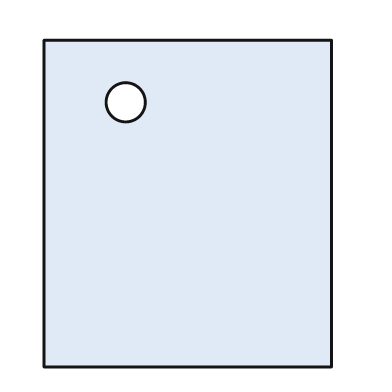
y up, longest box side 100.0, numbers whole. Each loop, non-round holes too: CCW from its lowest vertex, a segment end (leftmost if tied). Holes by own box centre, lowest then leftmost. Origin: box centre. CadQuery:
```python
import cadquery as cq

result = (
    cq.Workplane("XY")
    .moveTo(-44.0, -50.0)
    .lineTo(44.0, -50.0)
    .lineTo(44.0, 50.0)
    .lineTo(-44.0, 50.0)
    .close()
    .moveTo(-19.0, 31.0)
    .circle(6.0)
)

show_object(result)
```